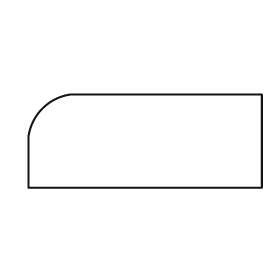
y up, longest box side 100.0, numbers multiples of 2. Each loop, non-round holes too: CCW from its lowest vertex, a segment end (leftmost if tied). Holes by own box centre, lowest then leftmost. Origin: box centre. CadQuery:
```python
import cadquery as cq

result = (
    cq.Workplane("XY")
    .moveTo(-50.0, -20.0)
    .lineTo(50.0, -20.0)
    .lineTo(50.0, 20.0)
    .lineTo(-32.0, 20.0)
    .threePointArc((-44.0, 14.0), (-50.0, 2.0))
    .close()
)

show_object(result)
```